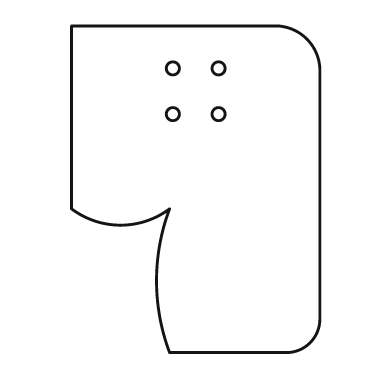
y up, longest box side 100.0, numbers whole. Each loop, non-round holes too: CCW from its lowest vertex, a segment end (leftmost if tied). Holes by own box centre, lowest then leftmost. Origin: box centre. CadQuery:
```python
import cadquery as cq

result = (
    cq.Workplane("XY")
    .moveTo(-8.0, -50.0)
    .lineTo(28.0, -50.0)
    .threePointArc((35.0, -47.0), (38.0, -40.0))
    .lineTo(38.0, 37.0)
    .threePointArc((34.0, 46.0), (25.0, 50.0))
    .lineTo(-38.0, 50.0)
    .lineTo(-38.0, -6.0)
    .threePointArc((-23.0, -11.0), (-8.0, -6.0))
    .threePointArc((-12.0, -28.0), (-8.0, -50.0))
    .close()
    .moveTo(-7.0, 23.0)
    .circle(2.0)
    .moveTo(7.0, 23.0)
    .circle(2.0)
    .moveTo(-7.0, 37.0)
    .circle(2.0)
    .moveTo(7.0, 37.0)
    .circle(2.0)
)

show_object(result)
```